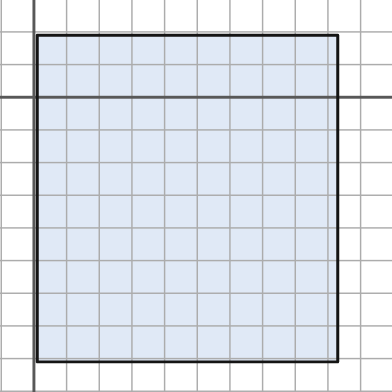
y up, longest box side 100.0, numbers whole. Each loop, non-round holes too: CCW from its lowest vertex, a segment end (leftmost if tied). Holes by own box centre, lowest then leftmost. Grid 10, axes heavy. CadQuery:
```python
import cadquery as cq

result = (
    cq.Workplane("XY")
    .moveTo(1.0, -81.0)
    .lineTo(93.0, -81.0)
    .lineTo(93.0, 19.0)
    .lineTo(1.0, 19.0)
    .close()
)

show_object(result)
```